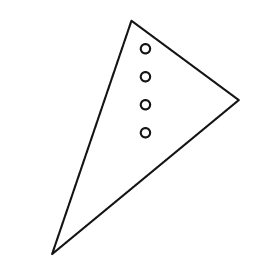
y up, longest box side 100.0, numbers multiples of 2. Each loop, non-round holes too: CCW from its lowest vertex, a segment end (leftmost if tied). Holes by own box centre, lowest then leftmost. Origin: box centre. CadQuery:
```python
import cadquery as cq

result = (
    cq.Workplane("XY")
    .moveTo(-40.0, -50.0)
    .lineTo(40.0, 16.0)
    .lineTo(-6.0, 50.0)
    .close()
    .moveTo(0.0, 2.0)
    .circle(2.0)
    .moveTo(0.0, 14.0)
    .circle(2.0)
    .moveTo(0.0, 26.0)
    .circle(2.0)
    .moveTo(0.0, 38.0)
    .circle(2.0)
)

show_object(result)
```